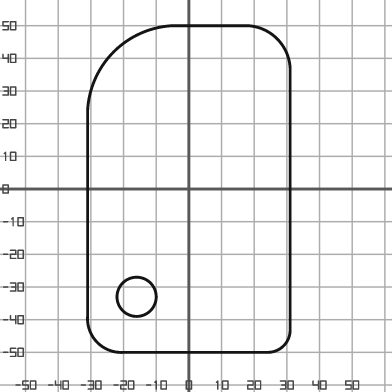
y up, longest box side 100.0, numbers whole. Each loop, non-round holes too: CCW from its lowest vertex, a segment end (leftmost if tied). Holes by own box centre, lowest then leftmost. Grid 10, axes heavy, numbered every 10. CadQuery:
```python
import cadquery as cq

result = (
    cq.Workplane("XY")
    .moveTo(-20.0, -50.0)
    .lineTo(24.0, -50.0)
    .threePointArc((29.0, -48.0), (31.0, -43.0))
    .lineTo(31.0, 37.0)
    .threePointArc((27.0, 46.0), (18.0, 50.0))
    .lineTo(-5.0, 50.0)
    .threePointArc((-23.0, 42.0), (-31.0, 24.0))
    .lineTo(-31.0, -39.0)
    .threePointArc((-28.0, -47.0), (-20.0, -50.0))
    .close()
    .moveTo(-16.0, -33.0)
    .circle(6.0)
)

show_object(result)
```